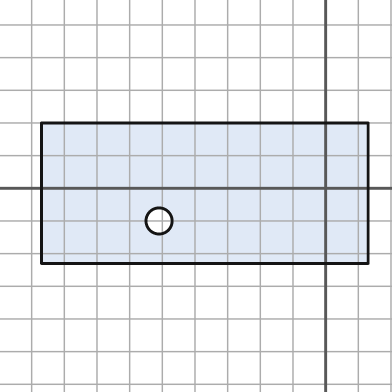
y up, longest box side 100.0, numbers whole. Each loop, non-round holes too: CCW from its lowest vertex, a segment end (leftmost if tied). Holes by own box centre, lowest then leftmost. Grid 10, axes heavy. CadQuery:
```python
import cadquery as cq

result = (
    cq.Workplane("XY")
    .moveTo(-87.0, -23.0)
    .lineTo(13.0, -23.0)
    .lineTo(13.0, 20.0)
    .lineTo(-87.0, 20.0)
    .close()
    .moveTo(-51.0, -10.0)
    .circle(4.0)
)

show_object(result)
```